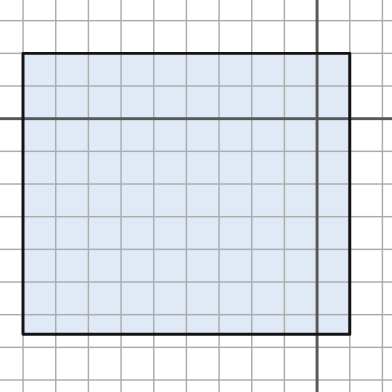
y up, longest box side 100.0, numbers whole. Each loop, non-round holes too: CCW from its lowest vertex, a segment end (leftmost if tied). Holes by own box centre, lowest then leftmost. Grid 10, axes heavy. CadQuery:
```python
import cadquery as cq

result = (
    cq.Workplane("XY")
    .moveTo(-90.0, -66.0)
    .lineTo(10.0, -66.0)
    .lineTo(10.0, 20.0)
    .lineTo(-90.0, 20.0)
    .close()
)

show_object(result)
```